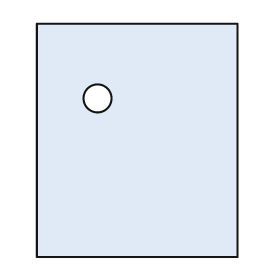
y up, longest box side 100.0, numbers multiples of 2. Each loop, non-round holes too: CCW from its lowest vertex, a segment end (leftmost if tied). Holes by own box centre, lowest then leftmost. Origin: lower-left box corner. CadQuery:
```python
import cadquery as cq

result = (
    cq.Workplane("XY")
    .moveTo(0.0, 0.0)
    .lineTo(86.0, 0.0)
    .lineTo(86.0, 100.0)
    .lineTo(0.0, 100.0)
    .close()
    .moveTo(26.0, 68.0)
    .circle(6.0)
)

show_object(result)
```